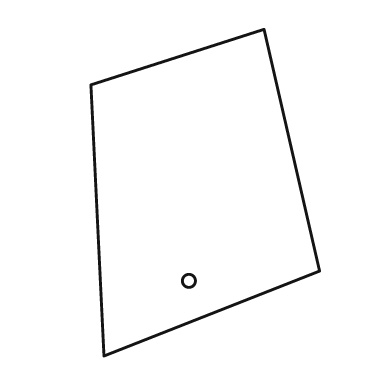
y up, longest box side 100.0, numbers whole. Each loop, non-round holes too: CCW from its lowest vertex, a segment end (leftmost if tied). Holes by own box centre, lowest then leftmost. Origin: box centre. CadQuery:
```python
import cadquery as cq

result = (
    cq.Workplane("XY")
    .moveTo(-31.0, -50.0)
    .lineTo(35.0, -24.0)
    .lineTo(18.0, 50.0)
    .lineTo(-35.0, 33.0)
    .close()
    .moveTo(-5.0, -27.0)
    .circle(2.0)
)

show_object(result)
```